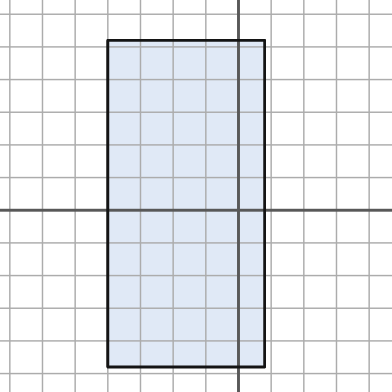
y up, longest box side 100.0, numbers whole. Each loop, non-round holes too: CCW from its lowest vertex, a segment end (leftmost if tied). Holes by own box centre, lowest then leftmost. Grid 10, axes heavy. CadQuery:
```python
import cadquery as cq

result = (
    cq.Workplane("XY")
    .moveTo(-40.0, -48.0)
    .lineTo(8.0, -48.0)
    .lineTo(8.0, 52.0)
    .lineTo(-40.0, 52.0)
    .close()
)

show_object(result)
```